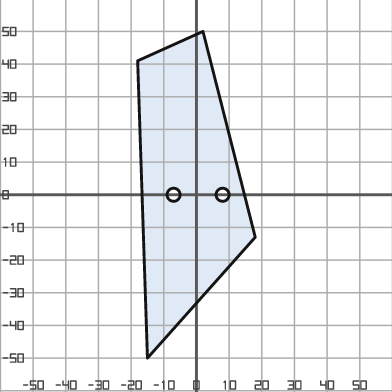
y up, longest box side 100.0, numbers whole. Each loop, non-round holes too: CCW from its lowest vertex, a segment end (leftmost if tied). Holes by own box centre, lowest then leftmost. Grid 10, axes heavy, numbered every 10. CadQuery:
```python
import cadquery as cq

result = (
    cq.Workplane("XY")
    .moveTo(-15.0, -50.0)
    .lineTo(18.0, -13.0)
    .lineTo(2.0, 50.0)
    .lineTo(-18.0, 41.0)
    .close()
    .moveTo(-7.0, 0.0)
    .circle(2.0)
    .moveTo(8.0, 0.0)
    .circle(2.0)
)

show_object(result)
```